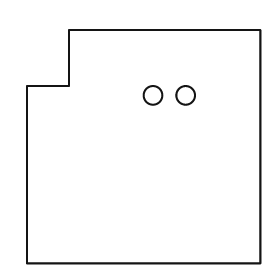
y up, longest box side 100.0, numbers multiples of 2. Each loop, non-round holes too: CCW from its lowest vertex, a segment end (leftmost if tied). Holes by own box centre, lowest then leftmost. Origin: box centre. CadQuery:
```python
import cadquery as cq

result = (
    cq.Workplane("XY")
    .moveTo(-50.0, -50.0)
    .lineTo(50.0, -50.0)
    .lineTo(50.0, 50.0)
    .lineTo(-32.0, 50.0)
    .lineTo(-32.0, 26.0)
    .lineTo(-50.0, 26.0)
    .close()
    .moveTo(4.0, 22.0)
    .circle(4.0)
    .moveTo(18.0, 22.0)
    .circle(4.0)
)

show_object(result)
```